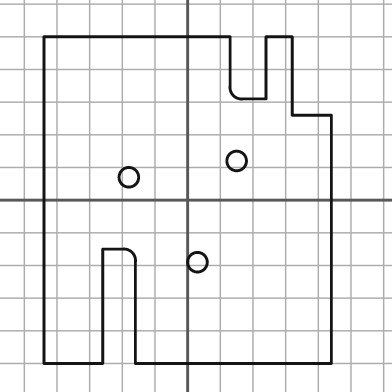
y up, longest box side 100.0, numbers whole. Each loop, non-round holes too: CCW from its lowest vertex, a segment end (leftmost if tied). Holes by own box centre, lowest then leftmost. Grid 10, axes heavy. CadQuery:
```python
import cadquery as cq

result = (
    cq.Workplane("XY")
    .moveTo(-44.0, -50.0)
    .lineTo(-26.0, -50.0)
    .lineTo(-26.0, -15.0)
    .lineTo(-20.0, -15.0)
    .threePointArc((-17.0, -16.0), (-16.0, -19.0))
    .lineTo(-16.0, -50.0)
    .lineTo(44.0, -50.0)
    .lineTo(44.0, 26.0)
    .lineTo(32.0, 26.0)
    .lineTo(32.0, 50.0)
    .lineTo(24.0, 50.0)
    .lineTo(24.0, 31.0)
    .lineTo(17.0, 31.0)
    .threePointArc((14.0, 32.0), (13.0, 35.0))
    .lineTo(13.0, 50.0)
    .lineTo(-44.0, 50.0)
    .close()
    .moveTo(3.0, -19.0)
    .circle(3.0)
    .moveTo(-18.0, 7.0)
    .circle(3.0)
    .moveTo(15.0, 12.0)
    .circle(3.0)
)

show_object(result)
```